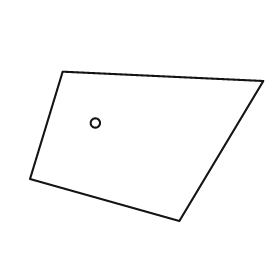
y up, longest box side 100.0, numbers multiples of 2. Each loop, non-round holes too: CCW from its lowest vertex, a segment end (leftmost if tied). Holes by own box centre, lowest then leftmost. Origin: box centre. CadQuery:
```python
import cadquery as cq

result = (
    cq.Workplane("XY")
    .moveTo(14.0, -32.0)
    .lineTo(50.0, 28.0)
    .lineTo(-36.0, 32.0)
    .lineTo(-50.0, -14.0)
    .close()
    .moveTo(-22.0, 10.0)
    .circle(2.0)
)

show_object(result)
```